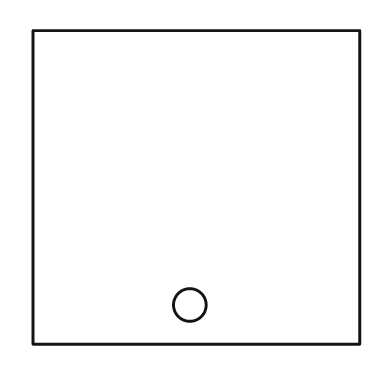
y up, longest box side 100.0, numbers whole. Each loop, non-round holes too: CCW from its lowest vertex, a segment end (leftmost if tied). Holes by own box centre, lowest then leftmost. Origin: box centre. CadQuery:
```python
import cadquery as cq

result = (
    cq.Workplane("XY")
    .moveTo(-50.0, -48.0)
    .lineTo(50.0, -48.0)
    .lineTo(50.0, 48.0)
    .lineTo(-50.0, 48.0)
    .close()
    .moveTo(-2.0, -36.0)
    .circle(5.0)
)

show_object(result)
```